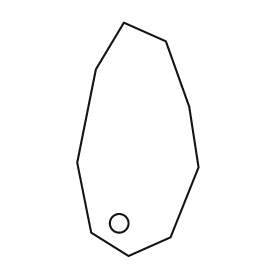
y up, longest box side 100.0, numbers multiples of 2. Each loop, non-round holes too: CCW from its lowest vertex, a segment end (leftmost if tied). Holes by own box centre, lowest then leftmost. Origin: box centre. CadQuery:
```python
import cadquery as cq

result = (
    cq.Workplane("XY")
    .moveTo(-4.0, -50.0)
    .lineTo(14.0, -42.0)
    .lineTo(26.0, -12.0)
    .lineTo(22.0, 14.0)
    .lineTo(12.0, 42.0)
    .lineTo(-6.0, 50.0)
    .lineTo(-18.0, 30.0)
    .lineTo(-26.0, -10.0)
    .lineTo(-20.0, -40.0)
    .close()
    .moveTo(-8.0, -36.0)
    .circle(4.0)
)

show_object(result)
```